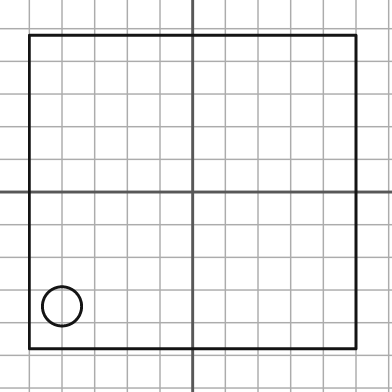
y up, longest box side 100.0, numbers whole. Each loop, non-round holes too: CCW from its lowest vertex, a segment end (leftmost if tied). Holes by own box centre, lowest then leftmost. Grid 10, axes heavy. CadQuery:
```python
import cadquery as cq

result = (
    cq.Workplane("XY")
    .moveTo(-50.0, -48.0)
    .lineTo(50.0, -48.0)
    .lineTo(50.0, 48.0)
    .lineTo(-50.0, 48.0)
    .close()
    .moveTo(-40.0, -35.0)
    .circle(6.0)
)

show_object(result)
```